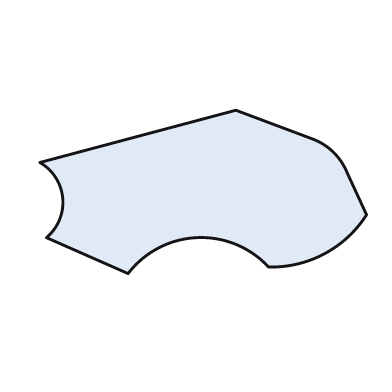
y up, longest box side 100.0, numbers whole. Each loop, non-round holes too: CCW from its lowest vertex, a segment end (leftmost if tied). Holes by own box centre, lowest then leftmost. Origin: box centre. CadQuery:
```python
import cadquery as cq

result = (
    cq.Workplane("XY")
    .moveTo(-23.0, -25.0)
    .threePointArc((-2.0, -14.0), (20.0, -23.0))
    .threePointArc((37.0, -19.0), (50.0, -7.0))
    .lineTo(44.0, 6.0)
    .threePointArc((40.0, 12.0), (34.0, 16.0))
    .lineTo(10.0, 25.0)
    .lineTo(-50.0, 9.0)
    .threePointArc((-43.0, -2.0), (-48.0, -14.0))
    .close()
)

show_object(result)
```